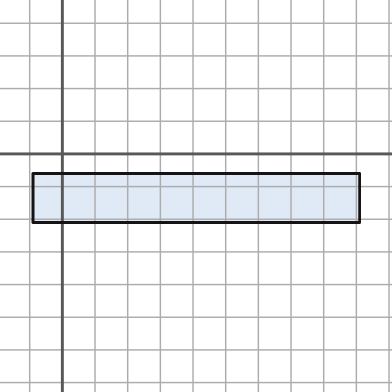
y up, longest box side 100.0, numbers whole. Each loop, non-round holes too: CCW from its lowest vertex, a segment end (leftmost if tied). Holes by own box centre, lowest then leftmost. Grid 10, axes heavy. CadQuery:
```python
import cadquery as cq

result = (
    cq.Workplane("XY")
    .moveTo(-9.0, -21.0)
    .lineTo(91.0, -21.0)
    .lineTo(91.0, -6.0)
    .lineTo(-9.0, -6.0)
    .close()
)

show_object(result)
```